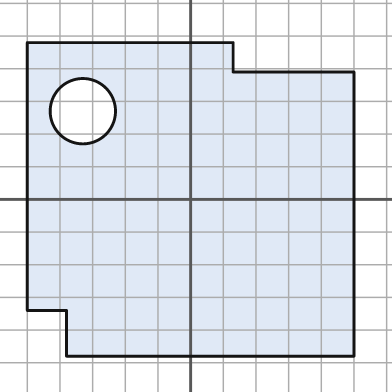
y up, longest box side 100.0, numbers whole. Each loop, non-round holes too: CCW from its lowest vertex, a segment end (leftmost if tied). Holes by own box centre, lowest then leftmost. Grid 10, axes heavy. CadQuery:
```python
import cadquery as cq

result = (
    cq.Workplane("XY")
    .moveTo(-38.0, -48.0)
    .lineTo(50.0, -48.0)
    .lineTo(50.0, 39.0)
    .lineTo(13.0, 39.0)
    .lineTo(13.0, 48.0)
    .lineTo(-50.0, 48.0)
    .lineTo(-50.0, -34.0)
    .lineTo(-38.0, -34.0)
    .close()
    .moveTo(-33.0, 27.0)
    .circle(10.0)
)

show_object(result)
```